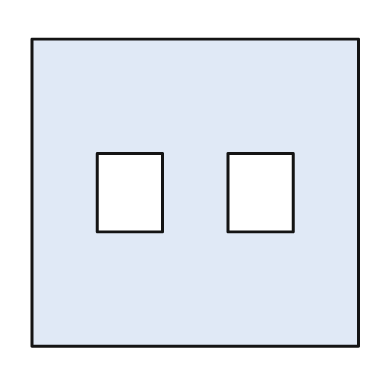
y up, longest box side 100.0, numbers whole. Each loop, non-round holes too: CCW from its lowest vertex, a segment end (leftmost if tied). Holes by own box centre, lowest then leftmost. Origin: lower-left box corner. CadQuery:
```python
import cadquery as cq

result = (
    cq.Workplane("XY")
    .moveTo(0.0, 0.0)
    .lineTo(100.0, 0.0)
    .lineTo(100.0, 94.0)
    .lineTo(0.0, 94.0)
    .close()
    .moveTo(20.0, 35.0)
    .lineTo(40.0, 35.0)
    .lineTo(40.0, 59.0)
    .lineTo(20.0, 59.0)
    .close()
    .moveTo(60.0, 35.0)
    .lineTo(80.0, 35.0)
    .lineTo(80.0, 59.0)
    .lineTo(60.0, 59.0)
    .close()
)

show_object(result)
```